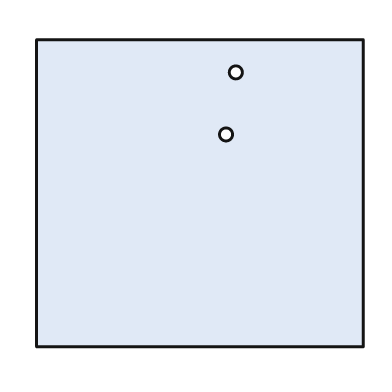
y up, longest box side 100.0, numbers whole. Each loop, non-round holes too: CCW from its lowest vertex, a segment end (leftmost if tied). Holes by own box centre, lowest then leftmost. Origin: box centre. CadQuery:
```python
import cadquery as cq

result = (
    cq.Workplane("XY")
    .moveTo(-50.0, -47.0)
    .lineTo(50.0, -47.0)
    .lineTo(50.0, 47.0)
    .lineTo(-50.0, 47.0)
    .close()
    .moveTo(8.0, 18.0)
    .circle(2.0)
    .moveTo(11.0, 37.0)
    .circle(2.0)
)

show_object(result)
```